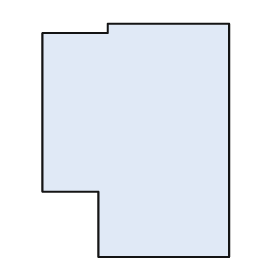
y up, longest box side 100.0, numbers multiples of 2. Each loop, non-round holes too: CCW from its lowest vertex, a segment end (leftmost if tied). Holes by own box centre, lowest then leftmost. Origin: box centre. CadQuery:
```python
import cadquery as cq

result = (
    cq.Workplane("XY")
    .moveTo(-16.0, -50.0)
    .lineTo(40.0, -50.0)
    .lineTo(40.0, 50.0)
    .lineTo(-12.0, 50.0)
    .lineTo(-12.0, 46.0)
    .lineTo(-40.0, 46.0)
    .lineTo(-40.0, -22.0)
    .lineTo(-16.0, -22.0)
    .close()
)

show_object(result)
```